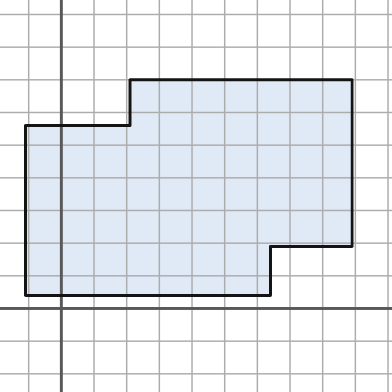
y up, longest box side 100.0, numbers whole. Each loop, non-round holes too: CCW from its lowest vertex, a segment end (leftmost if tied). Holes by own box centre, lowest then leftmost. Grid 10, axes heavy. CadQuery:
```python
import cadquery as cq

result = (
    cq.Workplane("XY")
    .moveTo(-11.0, 4.0)
    .lineTo(64.0, 4.0)
    .lineTo(64.0, 19.0)
    .lineTo(89.0, 19.0)
    .lineTo(89.0, 70.0)
    .lineTo(21.0, 70.0)
    .lineTo(21.0, 56.0)
    .lineTo(-11.0, 56.0)
    .close()
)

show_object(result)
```